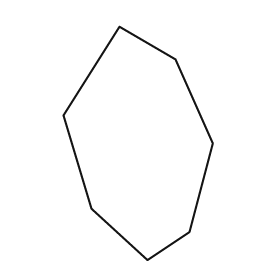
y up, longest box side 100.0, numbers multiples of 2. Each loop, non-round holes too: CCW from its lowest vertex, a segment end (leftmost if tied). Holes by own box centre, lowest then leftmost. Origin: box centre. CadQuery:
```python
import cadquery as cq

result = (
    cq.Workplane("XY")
    .moveTo(4.0, -50.0)
    .lineTo(22.0, -38.0)
    .lineTo(32.0, 0.0)
    .lineTo(16.0, 36.0)
    .lineTo(-8.0, 50.0)
    .lineTo(-32.0, 12.0)
    .lineTo(-20.0, -28.0)
    .close()
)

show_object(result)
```